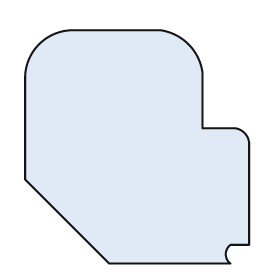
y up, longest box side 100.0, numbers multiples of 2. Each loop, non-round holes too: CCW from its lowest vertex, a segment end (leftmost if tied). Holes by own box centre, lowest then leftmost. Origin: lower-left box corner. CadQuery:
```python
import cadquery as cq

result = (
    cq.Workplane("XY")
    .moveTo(36.0, 0.0)
    .lineTo(88.0, 0.0)
    .threePointArc((86.0, 4.0), (88.0, 8.0))
    .lineTo(96.0, 8.0)
    .lineTo(96.0, 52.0)
    .threePointArc((94.0, 56.0), (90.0, 58.0))
    .lineTo(76.0, 58.0)
    .lineTo(76.0, 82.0)
    .threePointArc((70.0, 94.0), (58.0, 100.0))
    .lineTo(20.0, 100.0)
    .threePointArc((6.0, 94.0), (0.0, 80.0))
    .lineTo(0.0, 36.0)
    .close()
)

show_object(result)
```